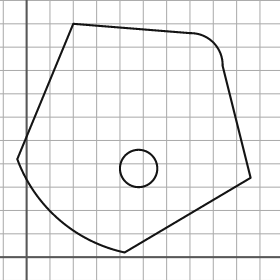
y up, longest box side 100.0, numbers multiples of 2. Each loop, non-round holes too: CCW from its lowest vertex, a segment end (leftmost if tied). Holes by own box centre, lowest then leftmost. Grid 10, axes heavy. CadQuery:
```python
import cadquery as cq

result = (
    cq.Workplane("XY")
    .moveTo(42.0, 2.0)
    .lineTo(96.0, 34.0)
    .lineTo(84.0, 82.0)
    .threePointArc((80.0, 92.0), (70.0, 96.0))
    .lineTo(20.0, 100.0)
    .lineTo(-4.0, 42.0)
    .threePointArc((14.0, 16.0), (42.0, 2.0))
    .close()
    .moveTo(48.0, 38.0)
    .circle(8.0)
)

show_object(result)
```